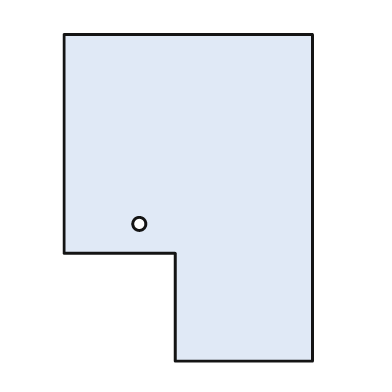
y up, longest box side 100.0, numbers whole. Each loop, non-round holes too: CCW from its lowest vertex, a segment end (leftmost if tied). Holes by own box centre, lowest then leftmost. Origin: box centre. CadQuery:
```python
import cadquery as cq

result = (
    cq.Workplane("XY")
    .moveTo(-4.0, -50.0)
    .lineTo(38.0, -50.0)
    .lineTo(38.0, 50.0)
    .lineTo(-38.0, 50.0)
    .lineTo(-38.0, -17.0)
    .lineTo(-4.0, -17.0)
    .close()
    .moveTo(-15.0, -8.0)
    .circle(2.0)
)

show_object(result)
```